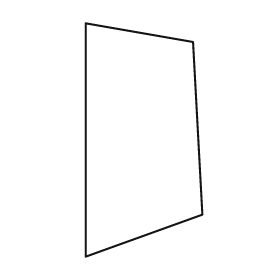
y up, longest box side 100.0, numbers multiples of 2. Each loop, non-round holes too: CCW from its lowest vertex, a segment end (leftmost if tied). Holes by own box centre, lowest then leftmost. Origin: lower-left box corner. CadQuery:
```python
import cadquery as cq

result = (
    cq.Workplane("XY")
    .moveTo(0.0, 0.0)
    .lineTo(50.0, 18.0)
    .lineTo(46.0, 92.0)
    .lineTo(0.0, 100.0)
    .close()
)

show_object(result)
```